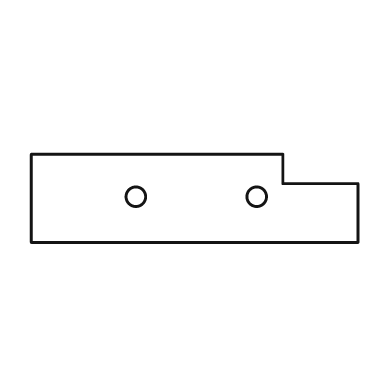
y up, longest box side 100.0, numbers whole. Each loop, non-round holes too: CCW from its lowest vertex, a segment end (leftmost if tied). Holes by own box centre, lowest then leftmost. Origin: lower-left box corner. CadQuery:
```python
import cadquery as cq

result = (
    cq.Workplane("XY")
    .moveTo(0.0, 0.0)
    .lineTo(100.0, 0.0)
    .lineTo(100.0, 18.0)
    .lineTo(77.0, 18.0)
    .lineTo(77.0, 27.0)
    .lineTo(0.0, 27.0)
    .close()
    .moveTo(32.0, 14.0)
    .circle(3.0)
    .moveTo(69.0, 14.0)
    .circle(3.0)
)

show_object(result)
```